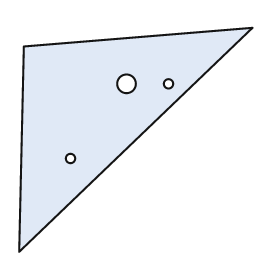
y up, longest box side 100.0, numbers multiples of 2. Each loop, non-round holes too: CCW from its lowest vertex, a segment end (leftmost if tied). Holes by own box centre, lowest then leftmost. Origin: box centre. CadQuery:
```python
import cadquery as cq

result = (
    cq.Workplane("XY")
    .moveTo(-50.0, -48.0)
    .lineTo(50.0, 48.0)
    .lineTo(-48.0, 40.0)
    .close()
    .moveTo(-28.0, -8.0)
    .circle(2.0)
    .moveTo(-4.0, 24.0)
    .circle(4.0)
    .moveTo(14.0, 24.0)
    .circle(2.0)
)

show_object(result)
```